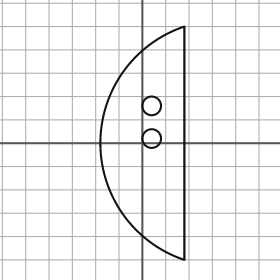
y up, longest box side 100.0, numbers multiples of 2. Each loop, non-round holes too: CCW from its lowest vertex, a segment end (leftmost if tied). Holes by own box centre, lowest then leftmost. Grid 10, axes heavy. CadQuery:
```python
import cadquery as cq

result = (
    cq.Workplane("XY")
    .moveTo(18.0, -50.0)
    .lineTo(18.0, 50.0)
    .threePointArc((-18.0, 0.0), (18.0, -50.0))
    .close()
    .moveTo(4.0, 2.0)
    .circle(4.0)
    .moveTo(4.0, 16.0)
    .circle(4.0)
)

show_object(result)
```